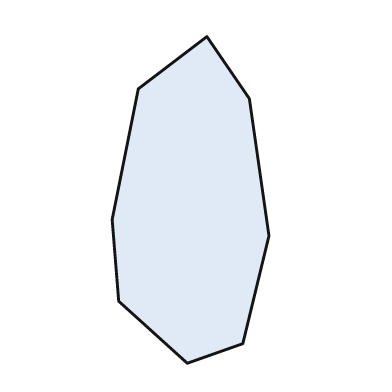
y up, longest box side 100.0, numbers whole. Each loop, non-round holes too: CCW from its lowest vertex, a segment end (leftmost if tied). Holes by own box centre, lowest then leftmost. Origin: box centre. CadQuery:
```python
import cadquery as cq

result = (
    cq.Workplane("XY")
    .moveTo(-1.0, -50.0)
    .lineTo(16.0, -44.0)
    .lineTo(24.0, -11.0)
    .lineTo(18.0, 31.0)
    .lineTo(5.0, 50.0)
    .lineTo(-16.0, 34.0)
    .lineTo(-24.0, -6.0)
    .lineTo(-22.0, -31.0)
    .close()
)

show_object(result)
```